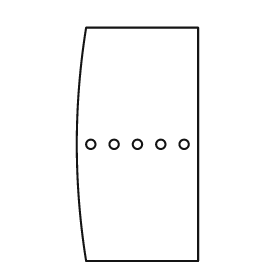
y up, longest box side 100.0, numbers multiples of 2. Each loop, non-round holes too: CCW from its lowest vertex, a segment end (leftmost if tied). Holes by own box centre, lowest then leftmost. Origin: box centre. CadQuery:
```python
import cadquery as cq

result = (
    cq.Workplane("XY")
    .moveTo(-22.0, -50.0)
    .lineTo(26.0, -50.0)
    .lineTo(26.0, 50.0)
    .lineTo(-22.0, 50.0)
    .threePointArc((-26.0, 0.0), (-22.0, -50.0))
    .close()
    .moveTo(-20.0, 0.0)
    .circle(2.0)
    .moveTo(-10.0, 0.0)
    .circle(2.0)
    .moveTo(0.0, 0.0)
    .circle(2.0)
    .moveTo(10.0, 0.0)
    .circle(2.0)
    .moveTo(20.0, 0.0)
    .circle(2.0)
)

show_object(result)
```